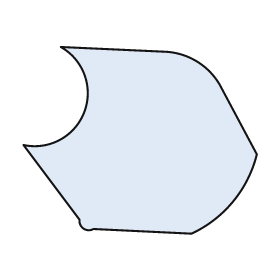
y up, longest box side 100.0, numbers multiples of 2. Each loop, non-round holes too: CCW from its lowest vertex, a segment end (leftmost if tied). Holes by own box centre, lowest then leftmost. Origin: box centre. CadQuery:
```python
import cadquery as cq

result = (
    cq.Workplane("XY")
    .moveTo(22.0, -40.0)
    .threePointArc((40.0, -26.0), (50.0, -6.0))
    .lineTo(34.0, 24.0)
    .threePointArc((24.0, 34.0), (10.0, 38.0))
    .lineTo(-34.0, 40.0)
    .threePointArc((-24.0, 12.0), (-50.0, -2.0))
    .lineTo(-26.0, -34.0)
    .threePointArc((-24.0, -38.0), (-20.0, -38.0))
    .close()
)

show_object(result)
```